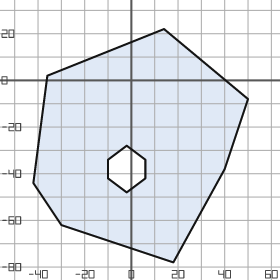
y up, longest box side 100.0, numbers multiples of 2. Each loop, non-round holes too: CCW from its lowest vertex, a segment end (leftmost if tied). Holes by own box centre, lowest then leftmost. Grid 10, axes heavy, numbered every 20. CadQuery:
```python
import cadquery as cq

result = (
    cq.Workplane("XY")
    .moveTo(18.0, -78.0)
    .lineTo(40.0, -38.0)
    .lineTo(50.0, -8.0)
    .lineTo(14.0, 22.0)
    .lineTo(-36.0, 2.0)
    .lineTo(-42.0, -44.0)
    .lineTo(-30.0, -62.0)
    .close()
    .moveTo(-2.0, -48.0)
    .lineTo(6.0, -42.0)
    .lineTo(6.0, -34.0)
    .lineTo(-2.0, -28.0)
    .lineTo(-10.0, -34.0)
    .lineTo(-10.0, -42.0)
    .close()
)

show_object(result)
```